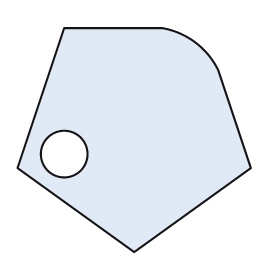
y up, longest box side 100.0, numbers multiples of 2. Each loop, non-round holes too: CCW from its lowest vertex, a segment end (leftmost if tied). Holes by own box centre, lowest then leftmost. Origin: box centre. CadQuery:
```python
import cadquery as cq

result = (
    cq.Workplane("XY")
    .moveTo(0.0, -48.0)
    .lineTo(50.0, -12.0)
    .lineTo(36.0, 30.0)
    .threePointArc((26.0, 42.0), (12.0, 48.0))
    .lineTo(-30.0, 48.0)
    .lineTo(-50.0, -12.0)
    .close()
    .moveTo(-30.0, -6.0)
    .circle(10.0)
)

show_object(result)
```